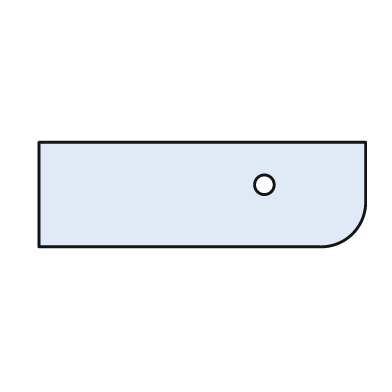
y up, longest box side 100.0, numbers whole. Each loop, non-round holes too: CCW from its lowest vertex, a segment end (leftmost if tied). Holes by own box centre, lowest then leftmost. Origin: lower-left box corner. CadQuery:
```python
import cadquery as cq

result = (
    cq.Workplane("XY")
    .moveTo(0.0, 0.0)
    .lineTo(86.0, 0.0)
    .threePointArc((96.0, 4.0), (100.0, 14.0))
    .lineTo(100.0, 32.0)
    .lineTo(0.0, 32.0)
    .close()
    .moveTo(69.0, 19.0)
    .circle(3.0)
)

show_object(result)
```